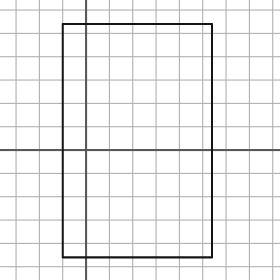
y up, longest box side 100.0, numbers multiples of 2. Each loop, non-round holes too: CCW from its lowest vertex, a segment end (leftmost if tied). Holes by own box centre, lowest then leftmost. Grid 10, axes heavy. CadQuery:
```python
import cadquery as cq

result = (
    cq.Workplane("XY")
    .moveTo(-10.0, -46.0)
    .lineTo(54.0, -46.0)
    .lineTo(54.0, 54.0)
    .lineTo(-10.0, 54.0)
    .close()
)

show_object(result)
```